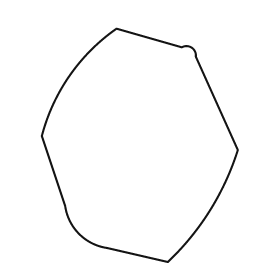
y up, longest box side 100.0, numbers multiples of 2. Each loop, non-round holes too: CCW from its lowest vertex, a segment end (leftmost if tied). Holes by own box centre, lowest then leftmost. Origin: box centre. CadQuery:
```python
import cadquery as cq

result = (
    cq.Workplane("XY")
    .moveTo(12.0, -50.0)
    .threePointArc((30.0, -28.0), (42.0, -2.0))
    .lineTo(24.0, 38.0)
    .threePointArc((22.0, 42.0), (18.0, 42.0))
    .lineTo(-10.0, 50.0)
    .threePointArc((-30.0, 30.0), (-42.0, 4.0))
    .lineTo(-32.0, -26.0)
    .threePointArc((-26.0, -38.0), (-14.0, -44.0))
    .close()
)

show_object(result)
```